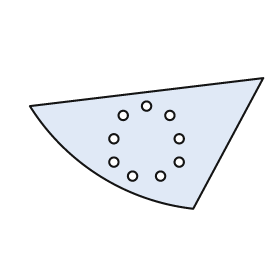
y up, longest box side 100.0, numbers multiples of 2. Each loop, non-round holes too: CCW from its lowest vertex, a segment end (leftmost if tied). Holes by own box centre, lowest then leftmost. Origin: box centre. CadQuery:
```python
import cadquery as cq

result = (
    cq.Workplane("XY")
    .moveTo(20.0, -28.0)
    .lineTo(50.0, 28.0)
    .lineTo(-50.0, 16.0)
    .threePointArc((-20.0, -14.0), (20.0, -28.0))
    .close()
    .moveTo(-6.0, -14.0)
    .circle(2.0)
    .moveTo(6.0, -14.0)
    .circle(2.0)
    .moveTo(-14.0, -8.0)
    .circle(2.0)
    .moveTo(14.0, -8.0)
    .circle(2.0)
    .moveTo(-14.0, 2.0)
    .circle(2.0)
    .moveTo(14.0, 2.0)
    .circle(2.0)
    .moveTo(-10.0, 12.0)
    .circle(2.0)
    .moveTo(10.0, 12.0)
    .circle(2.0)
    .moveTo(0.0, 16.0)
    .circle(2.0)
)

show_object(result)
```